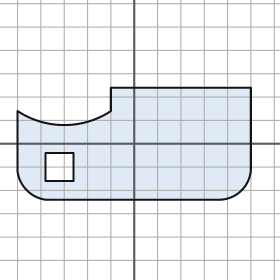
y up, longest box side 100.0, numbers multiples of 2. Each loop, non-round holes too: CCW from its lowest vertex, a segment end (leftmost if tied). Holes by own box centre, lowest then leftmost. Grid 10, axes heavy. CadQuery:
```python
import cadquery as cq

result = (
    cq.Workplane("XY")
    .moveTo(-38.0, -24.0)
    .lineTo(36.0, -24.0)
    .threePointArc((46.0, -20.0), (50.0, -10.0))
    .lineTo(50.0, 24.0)
    .lineTo(-10.0, 24.0)
    .lineTo(-10.0, 14.0)
    .threePointArc((-30.0, 8.0), (-50.0, 14.0))
    .lineTo(-50.0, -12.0)
    .threePointArc((-46.0, -20.0), (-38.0, -24.0))
    .close()
    .moveTo(-38.0, -16.0)
    .lineTo(-26.0, -16.0)
    .lineTo(-26.0, -4.0)
    .lineTo(-38.0, -4.0)
    .close()
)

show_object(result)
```